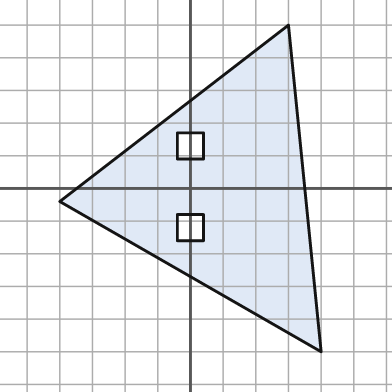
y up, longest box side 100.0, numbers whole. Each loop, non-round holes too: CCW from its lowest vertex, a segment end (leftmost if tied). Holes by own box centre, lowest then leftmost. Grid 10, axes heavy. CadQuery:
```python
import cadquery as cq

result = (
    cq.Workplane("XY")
    .moveTo(40.0, -50.0)
    .lineTo(30.0, 50.0)
    .lineTo(-40.0, -4.0)
    .close()
    .moveTo(-4.0, -16.0)
    .lineTo(4.0, -16.0)
    .lineTo(4.0, -8.0)
    .lineTo(-4.0, -8.0)
    .close()
    .moveTo(-4.0, 9.0)
    .lineTo(4.0, 9.0)
    .lineTo(4.0, 17.0)
    .lineTo(-4.0, 17.0)
    .close()
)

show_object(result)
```